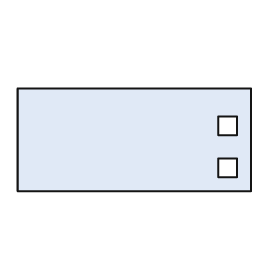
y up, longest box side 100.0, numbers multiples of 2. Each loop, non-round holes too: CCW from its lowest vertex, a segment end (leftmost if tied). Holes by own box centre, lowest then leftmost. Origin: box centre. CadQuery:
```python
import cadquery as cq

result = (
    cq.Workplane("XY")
    .moveTo(-50.0, -22.0)
    .lineTo(50.0, -22.0)
    .lineTo(50.0, 22.0)
    .lineTo(-50.0, 22.0)
    .close()
    .moveTo(36.0, -16.0)
    .lineTo(44.0, -16.0)
    .lineTo(44.0, -8.0)
    .lineTo(36.0, -8.0)
    .close()
    .moveTo(36.0, 2.0)
    .lineTo(44.0, 2.0)
    .lineTo(44.0, 10.0)
    .lineTo(36.0, 10.0)
    .close()
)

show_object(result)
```